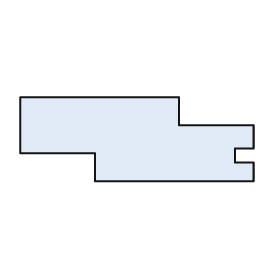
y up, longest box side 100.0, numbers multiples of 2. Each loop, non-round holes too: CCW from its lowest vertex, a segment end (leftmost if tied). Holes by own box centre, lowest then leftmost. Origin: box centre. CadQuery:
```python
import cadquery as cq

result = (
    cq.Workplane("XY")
    .moveTo(-18.0, -18.0)
    .lineTo(50.0, -18.0)
    .lineTo(50.0, -10.0)
    .lineTo(42.0, -10.0)
    .lineTo(42.0, -4.0)
    .lineTo(50.0, -4.0)
    .lineTo(50.0, 6.0)
    .lineTo(18.0, 6.0)
    .lineTo(18.0, 18.0)
    .lineTo(-50.0, 18.0)
    .lineTo(-50.0, -6.0)
    .lineTo(-18.0, -6.0)
    .close()
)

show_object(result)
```